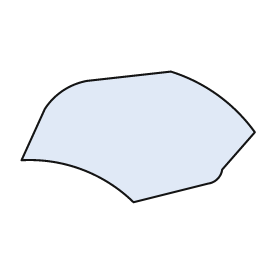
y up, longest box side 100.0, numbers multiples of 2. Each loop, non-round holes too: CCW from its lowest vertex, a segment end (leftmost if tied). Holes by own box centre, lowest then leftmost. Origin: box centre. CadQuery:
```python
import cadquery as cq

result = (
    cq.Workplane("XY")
    .moveTo(-2.0, -28.0)
    .lineTo(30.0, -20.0)
    .threePointArc((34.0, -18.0), (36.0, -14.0))
    .lineTo(50.0, 2.0)
    .threePointArc((34.0, 18.0), (14.0, 28.0))
    .lineTo(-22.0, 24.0)
    .threePointArc((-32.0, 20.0), (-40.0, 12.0))
    .lineTo(-50.0, -10.0)
    .threePointArc((-24.0, -14.0), (-2.0, -28.0))
    .close()
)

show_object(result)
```